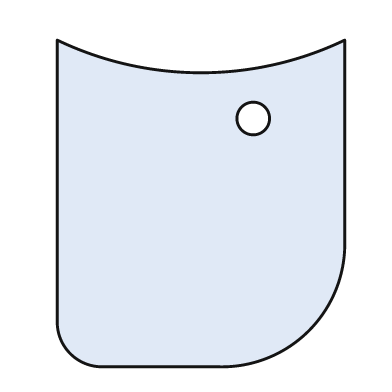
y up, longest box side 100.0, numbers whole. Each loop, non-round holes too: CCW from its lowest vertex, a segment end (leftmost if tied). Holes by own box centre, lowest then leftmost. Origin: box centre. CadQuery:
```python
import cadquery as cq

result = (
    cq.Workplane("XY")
    .moveTo(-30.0, -50.0)
    .lineTo(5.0, -50.0)
    .threePointArc((33.0, -39.0), (44.0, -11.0))
    .lineTo(44.0, 50.0)
    .threePointArc((0.0, 40.0), (-44.0, 50.0))
    .lineTo(-44.0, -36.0)
    .threePointArc((-40.0, -46.0), (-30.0, -50.0))
    .close()
    .moveTo(16.0, 26.0)
    .circle(5.0)
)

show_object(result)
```